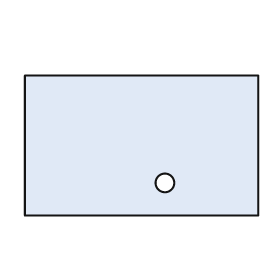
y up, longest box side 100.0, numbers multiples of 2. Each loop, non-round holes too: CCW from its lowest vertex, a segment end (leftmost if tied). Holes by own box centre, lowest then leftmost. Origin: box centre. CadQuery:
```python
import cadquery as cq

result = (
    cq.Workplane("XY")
    .moveTo(-50.0, -30.0)
    .lineTo(50.0, -30.0)
    .lineTo(50.0, 30.0)
    .lineTo(-50.0, 30.0)
    .close()
    .moveTo(10.0, -16.0)
    .circle(4.0)
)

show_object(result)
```